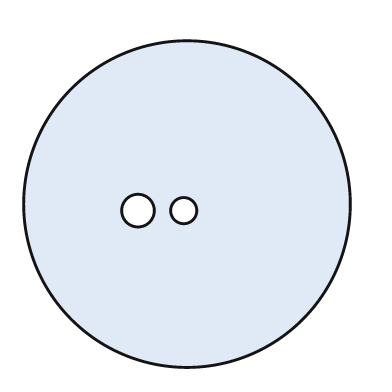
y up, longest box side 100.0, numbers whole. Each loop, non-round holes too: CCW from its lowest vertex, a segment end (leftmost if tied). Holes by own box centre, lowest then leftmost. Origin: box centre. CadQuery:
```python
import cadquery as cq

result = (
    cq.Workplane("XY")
    .moveTo(0.0, 0.0)
    .circle(50.0)
    .moveTo(-15.0, -2.0)
    .circle(5.0)
    .moveTo(-1.0, -2.0)
    .circle(4.0)
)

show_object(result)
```